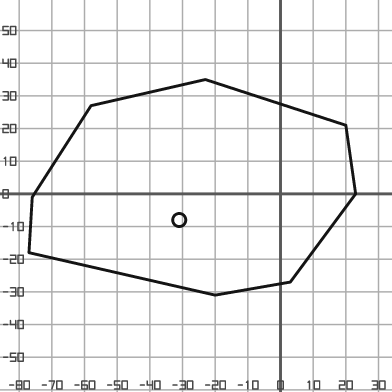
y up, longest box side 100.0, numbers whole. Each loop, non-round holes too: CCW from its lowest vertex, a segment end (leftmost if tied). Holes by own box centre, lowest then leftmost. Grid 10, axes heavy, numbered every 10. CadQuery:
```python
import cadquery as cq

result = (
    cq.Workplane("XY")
    .moveTo(-20.0, -31.0)
    .lineTo(3.0, -27.0)
    .lineTo(23.0, 0.0)
    .lineTo(20.0, 21.0)
    .lineTo(-23.0, 35.0)
    .lineTo(-58.0, 27.0)
    .lineTo(-76.0, -1.0)
    .lineTo(-77.0, -18.0)
    .close()
    .moveTo(-31.0, -8.0)
    .circle(2.0)
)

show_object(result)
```